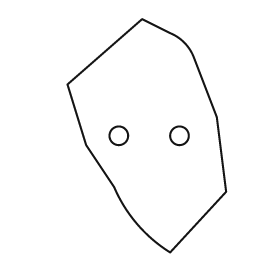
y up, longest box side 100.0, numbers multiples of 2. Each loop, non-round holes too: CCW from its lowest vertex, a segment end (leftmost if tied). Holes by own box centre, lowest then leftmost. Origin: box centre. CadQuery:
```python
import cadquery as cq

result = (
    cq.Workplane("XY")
    .moveTo(10.0, -50.0)
    .lineTo(34.0, -24.0)
    .lineTo(30.0, 8.0)
    .lineTo(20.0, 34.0)
    .threePointArc((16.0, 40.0), (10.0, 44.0))
    .lineTo(-2.0, 50.0)
    .lineTo(-34.0, 22.0)
    .lineTo(-26.0, -4.0)
    .lineTo(-14.0, -22.0)
    .threePointArc((-4.0, -38.0), (10.0, -50.0))
    .close()
    .moveTo(-12.0, 0.0)
    .circle(4.0)
    .moveTo(14.0, 0.0)
    .circle(4.0)
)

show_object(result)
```